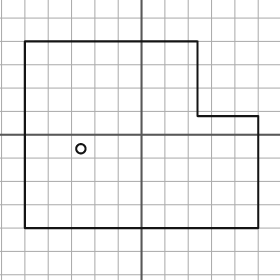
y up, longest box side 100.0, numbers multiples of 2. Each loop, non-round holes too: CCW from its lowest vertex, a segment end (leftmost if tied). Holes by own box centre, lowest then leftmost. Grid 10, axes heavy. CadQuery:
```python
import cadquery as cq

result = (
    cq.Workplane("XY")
    .moveTo(-50.0, -40.0)
    .lineTo(50.0, -40.0)
    .lineTo(50.0, 8.0)
    .lineTo(24.0, 8.0)
    .lineTo(24.0, 40.0)
    .lineTo(-50.0, 40.0)
    .close()
    .moveTo(-26.0, -6.0)
    .circle(2.0)
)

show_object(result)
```